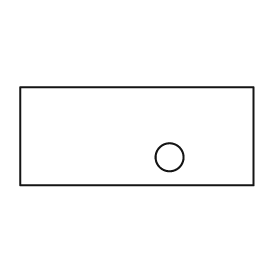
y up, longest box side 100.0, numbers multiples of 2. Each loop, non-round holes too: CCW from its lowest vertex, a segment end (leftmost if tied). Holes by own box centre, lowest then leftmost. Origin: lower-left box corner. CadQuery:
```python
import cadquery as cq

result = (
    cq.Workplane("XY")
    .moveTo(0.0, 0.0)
    .lineTo(100.0, 0.0)
    .lineTo(100.0, 42.0)
    .lineTo(0.0, 42.0)
    .close()
    .moveTo(64.0, 12.0)
    .circle(6.0)
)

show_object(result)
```